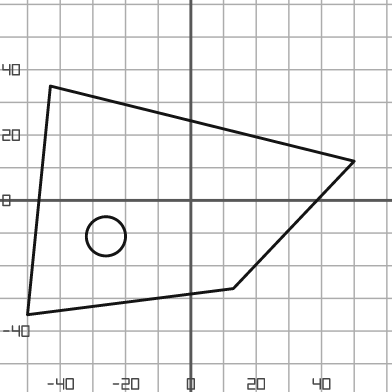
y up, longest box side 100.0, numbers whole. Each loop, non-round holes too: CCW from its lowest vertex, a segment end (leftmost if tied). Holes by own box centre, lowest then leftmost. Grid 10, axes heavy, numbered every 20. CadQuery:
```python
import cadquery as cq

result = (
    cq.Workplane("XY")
    .moveTo(-50.0, -35.0)
    .lineTo(13.0, -27.0)
    .lineTo(50.0, 12.0)
    .lineTo(-43.0, 35.0)
    .close()
    .moveTo(-26.0, -11.0)
    .circle(6.0)
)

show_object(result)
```